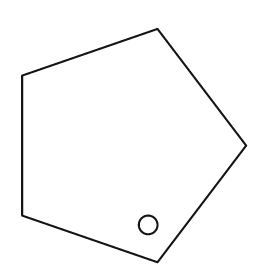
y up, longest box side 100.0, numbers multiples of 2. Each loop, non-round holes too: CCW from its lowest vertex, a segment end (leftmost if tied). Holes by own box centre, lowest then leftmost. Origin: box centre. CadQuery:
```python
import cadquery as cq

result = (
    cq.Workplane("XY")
    .moveTo(10.0, -50.0)
    .lineTo(48.0, 0.0)
    .lineTo(10.0, 50.0)
    .lineTo(-48.0, 30.0)
    .lineTo(-48.0, -30.0)
    .close()
    .moveTo(6.0, -34.0)
    .circle(4.0)
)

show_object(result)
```